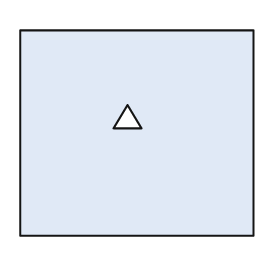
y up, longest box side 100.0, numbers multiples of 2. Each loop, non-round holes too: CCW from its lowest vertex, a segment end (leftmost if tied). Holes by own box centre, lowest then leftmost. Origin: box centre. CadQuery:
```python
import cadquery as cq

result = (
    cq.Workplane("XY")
    .moveTo(-50.0, -44.0)
    .lineTo(50.0, -44.0)
    .lineTo(50.0, 44.0)
    .lineTo(-50.0, 44.0)
    .close()
    .moveTo(-10.0, 2.0)
    .lineTo(2.0, 2.0)
    .lineTo(-4.0, 12.0)
    .close()
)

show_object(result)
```